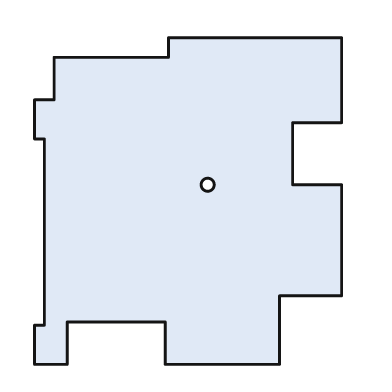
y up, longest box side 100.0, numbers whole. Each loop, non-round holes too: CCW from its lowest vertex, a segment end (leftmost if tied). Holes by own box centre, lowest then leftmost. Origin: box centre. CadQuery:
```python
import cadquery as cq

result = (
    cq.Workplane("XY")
    .moveTo(-47.0, -50.0)
    .lineTo(-37.0, -50.0)
    .lineTo(-37.0, -37.0)
    .lineTo(-7.0, -37.0)
    .lineTo(-7.0, -50.0)
    .lineTo(28.0, -50.0)
    .lineTo(28.0, -29.0)
    .lineTo(47.0, -29.0)
    .lineTo(47.0, 5.0)
    .lineTo(32.0, 5.0)
    .lineTo(32.0, 24.0)
    .lineTo(47.0, 24.0)
    .lineTo(47.0, 50.0)
    .lineTo(-6.0, 50.0)
    .lineTo(-6.0, 44.0)
    .lineTo(-41.0, 44.0)
    .lineTo(-41.0, 31.0)
    .lineTo(-47.0, 31.0)
    .lineTo(-47.0, 19.0)
    .lineTo(-44.0, 19.0)
    .lineTo(-44.0, -38.0)
    .lineTo(-47.0, -38.0)
    .close()
    .moveTo(6.0, 5.0)
    .circle(2.0)
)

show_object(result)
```